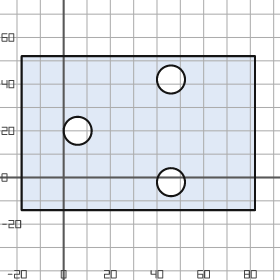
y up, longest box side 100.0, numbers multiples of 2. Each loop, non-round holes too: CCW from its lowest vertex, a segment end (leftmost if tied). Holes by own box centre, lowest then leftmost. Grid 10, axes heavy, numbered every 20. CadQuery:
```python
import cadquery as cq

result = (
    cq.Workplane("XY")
    .moveTo(-18.0, -14.0)
    .lineTo(82.0, -14.0)
    .lineTo(82.0, 52.0)
    .lineTo(-18.0, 52.0)
    .close()
    .moveTo(46.0, -2.0)
    .circle(6.0)
    .moveTo(6.0, 20.0)
    .circle(6.0)
    .moveTo(46.0, 42.0)
    .circle(6.0)
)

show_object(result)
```